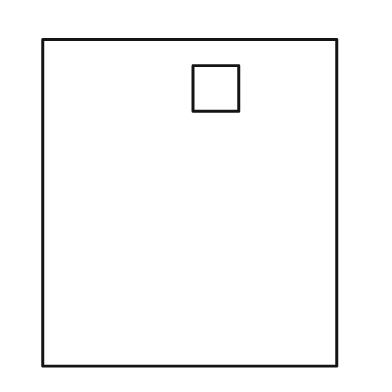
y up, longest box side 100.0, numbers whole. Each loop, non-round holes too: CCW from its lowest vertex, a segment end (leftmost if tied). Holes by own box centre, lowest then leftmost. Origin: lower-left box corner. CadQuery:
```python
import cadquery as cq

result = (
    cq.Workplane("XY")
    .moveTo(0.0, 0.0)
    .lineTo(90.0, 0.0)
    .lineTo(90.0, 100.0)
    .lineTo(0.0, 100.0)
    .close()
    .moveTo(46.0, 78.0)
    .lineTo(60.0, 78.0)
    .lineTo(60.0, 92.0)
    .lineTo(46.0, 92.0)
    .close()
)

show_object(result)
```